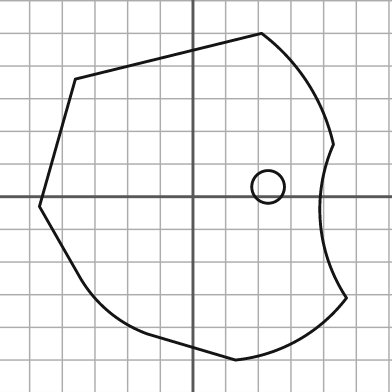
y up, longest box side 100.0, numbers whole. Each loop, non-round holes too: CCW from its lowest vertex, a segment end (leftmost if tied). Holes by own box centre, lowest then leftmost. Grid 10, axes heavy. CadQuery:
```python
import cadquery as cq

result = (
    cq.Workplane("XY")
    .moveTo(13.0, -50.0)
    .threePointArc((32.0, -44.0), (47.0, -31.0))
    .threePointArc((39.0, -8.0), (43.0, 16.0))
    .threePointArc((35.0, 35.0), (21.0, 50.0))
    .lineTo(-36.0, 36.0)
    .lineTo(-47.0, -3.0)
    .lineTo(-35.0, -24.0)
    .threePointArc((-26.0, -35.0), (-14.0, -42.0))
    .close()
    .moveTo(23.0, 3.0)
    .circle(5.0)
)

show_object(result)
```